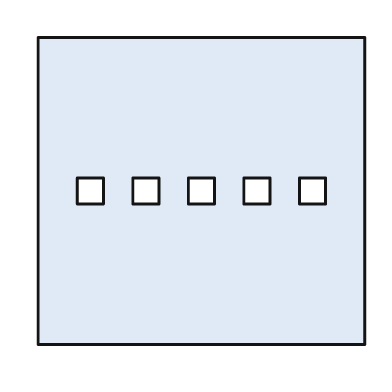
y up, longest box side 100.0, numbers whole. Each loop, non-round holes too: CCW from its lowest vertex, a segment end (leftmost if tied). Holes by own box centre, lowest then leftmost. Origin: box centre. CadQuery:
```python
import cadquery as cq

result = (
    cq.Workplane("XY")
    .moveTo(-50.0, -47.0)
    .lineTo(50.0, -47.0)
    .lineTo(50.0, 47.0)
    .lineTo(-50.0, 47.0)
    .close()
    .moveTo(-38.0, -4.0)
    .lineTo(-30.0, -4.0)
    .lineTo(-30.0, 4.0)
    .lineTo(-38.0, 4.0)
    .close()
    .moveTo(-21.0, -4.0)
    .lineTo(-13.0, -4.0)
    .lineTo(-13.0, 4.0)
    .lineTo(-21.0, 4.0)
    .close()
    .moveTo(-4.0, -4.0)
    .lineTo(4.0, -4.0)
    .lineTo(4.0, 4.0)
    .lineTo(-4.0, 4.0)
    .close()
    .moveTo(13.0, -4.0)
    .lineTo(21.0, -4.0)
    .lineTo(21.0, 4.0)
    .lineTo(13.0, 4.0)
    .close()
    .moveTo(30.0, -4.0)
    .lineTo(38.0, -4.0)
    .lineTo(38.0, 4.0)
    .lineTo(30.0, 4.0)
    .close()
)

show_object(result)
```